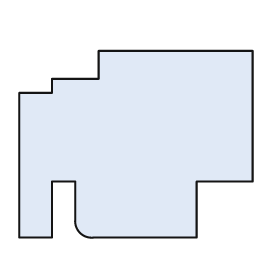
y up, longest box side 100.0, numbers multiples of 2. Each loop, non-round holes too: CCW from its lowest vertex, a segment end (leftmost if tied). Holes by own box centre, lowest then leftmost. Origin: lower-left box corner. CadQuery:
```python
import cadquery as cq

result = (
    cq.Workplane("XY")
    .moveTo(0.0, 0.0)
    .lineTo(14.0, 0.0)
    .lineTo(14.0, 24.0)
    .lineTo(24.0, 24.0)
    .lineTo(24.0, 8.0)
    .threePointArc((26.0, 2.0), (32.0, 0.0))
    .lineTo(76.0, 0.0)
    .lineTo(76.0, 24.0)
    .lineTo(100.0, 24.0)
    .lineTo(100.0, 80.0)
    .lineTo(34.0, 80.0)
    .lineTo(34.0, 68.0)
    .lineTo(14.0, 68.0)
    .lineTo(14.0, 62.0)
    .lineTo(0.0, 62.0)
    .close()
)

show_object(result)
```